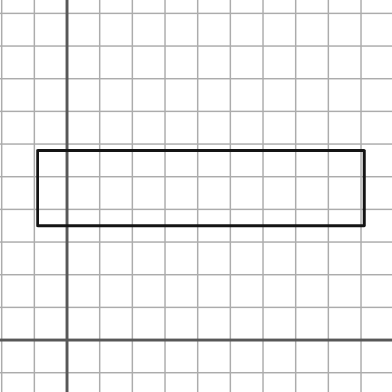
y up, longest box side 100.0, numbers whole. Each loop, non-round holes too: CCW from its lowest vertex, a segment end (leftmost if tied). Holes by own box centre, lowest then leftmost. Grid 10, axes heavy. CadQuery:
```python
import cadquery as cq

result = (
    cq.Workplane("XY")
    .moveTo(-9.0, 35.0)
    .lineTo(91.0, 35.0)
    .lineTo(91.0, 58.0)
    .lineTo(-9.0, 58.0)
    .close()
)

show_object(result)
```